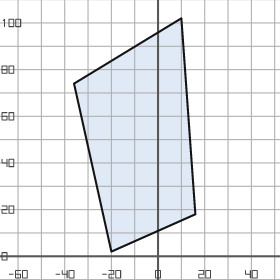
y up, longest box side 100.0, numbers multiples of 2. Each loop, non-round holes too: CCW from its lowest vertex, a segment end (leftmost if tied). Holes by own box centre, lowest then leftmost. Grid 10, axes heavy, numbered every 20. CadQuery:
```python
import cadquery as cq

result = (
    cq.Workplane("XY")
    .moveTo(-20.0, 2.0)
    .lineTo(16.0, 18.0)
    .lineTo(10.0, 102.0)
    .lineTo(-36.0, 74.0)
    .close()
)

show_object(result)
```